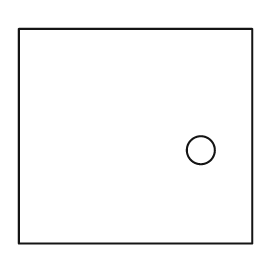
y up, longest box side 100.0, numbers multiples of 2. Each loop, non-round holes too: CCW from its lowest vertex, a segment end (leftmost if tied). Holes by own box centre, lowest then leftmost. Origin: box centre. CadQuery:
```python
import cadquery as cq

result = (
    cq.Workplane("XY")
    .moveTo(-50.0, -46.0)
    .lineTo(50.0, -46.0)
    .lineTo(50.0, 46.0)
    .lineTo(-50.0, 46.0)
    .close()
    .moveTo(28.0, -6.0)
    .circle(6.0)
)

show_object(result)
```